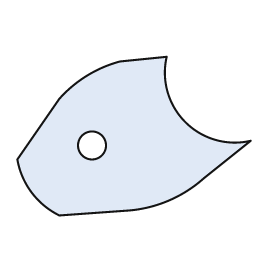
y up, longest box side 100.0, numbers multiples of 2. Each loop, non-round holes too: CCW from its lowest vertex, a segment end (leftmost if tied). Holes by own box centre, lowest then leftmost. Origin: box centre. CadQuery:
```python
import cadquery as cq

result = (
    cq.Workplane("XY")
    .moveTo(-32.0, -34.0)
    .lineTo(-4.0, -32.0)
    .threePointArc((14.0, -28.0), (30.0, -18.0))
    .lineTo(50.0, -2.0)
    .threePointArc((22.0, 6.0), (14.0, 34.0))
    .lineTo(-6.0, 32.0)
    .threePointArc((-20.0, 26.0), (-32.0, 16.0))
    .lineTo(-50.0, -10.0)
    .threePointArc((-44.0, -24.0), (-32.0, -34.0))
    .close()
    .moveTo(-18.0, -4.0)
    .circle(6.0)
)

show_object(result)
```